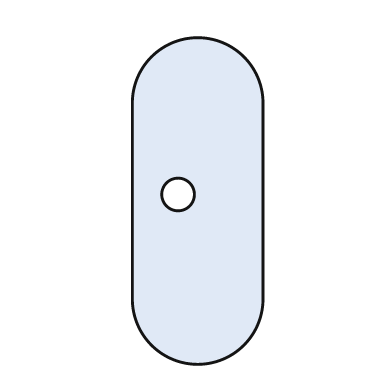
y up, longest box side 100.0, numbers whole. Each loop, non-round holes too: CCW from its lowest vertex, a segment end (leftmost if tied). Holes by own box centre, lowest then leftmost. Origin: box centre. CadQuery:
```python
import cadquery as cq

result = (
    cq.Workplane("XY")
    .moveTo(-20.0, -30.0)
    .threePointArc((0.0, -50.0), (20.0, -30.0))
    .lineTo(20.0, 30.0)
    .threePointArc((0.0, 50.0), (-20.0, 30.0))
    .close()
    .moveTo(-6.0, 2.0)
    .circle(5.0)
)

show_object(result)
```